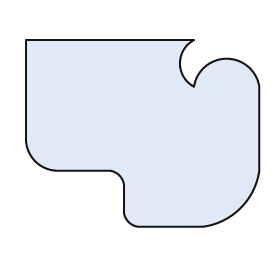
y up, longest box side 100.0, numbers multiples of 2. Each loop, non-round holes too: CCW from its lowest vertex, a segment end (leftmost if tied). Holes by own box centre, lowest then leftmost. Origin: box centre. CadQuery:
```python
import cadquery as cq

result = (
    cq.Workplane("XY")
    .moveTo(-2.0, -40.0)
    .lineTo(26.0, -40.0)
    .threePointArc((42.0, -32.0), (50.0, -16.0))
    .lineTo(50.0, 20.0)
    .threePointArc((36.0, 32.0), (22.0, 20.0))
    .threePointArc((16.0, 30.0), (22.0, 40.0))
    .lineTo(-50.0, 40.0)
    .lineTo(-50.0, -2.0)
    .threePointArc((-46.0, -12.0), (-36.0, -16.0))
    .lineTo(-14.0, -16.0)
    .threePointArc((-10.0, -18.0), (-8.0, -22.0))
    .lineTo(-8.0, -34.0)
    .threePointArc((-6.0, -38.0), (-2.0, -40.0))
    .close()
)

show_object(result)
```